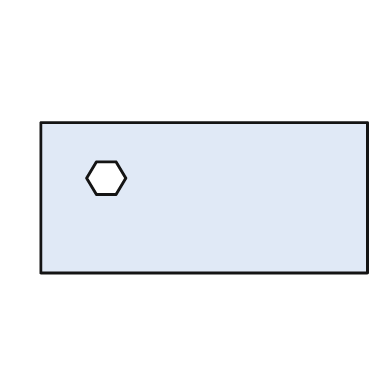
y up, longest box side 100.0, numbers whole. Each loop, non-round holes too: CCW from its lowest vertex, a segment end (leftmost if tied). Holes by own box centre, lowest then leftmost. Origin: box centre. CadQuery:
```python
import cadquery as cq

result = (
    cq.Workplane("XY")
    .moveTo(-50.0, -23.0)
    .lineTo(50.0, -23.0)
    .lineTo(50.0, 23.0)
    .lineTo(-50.0, 23.0)
    .close()
    .moveTo(-33.0, 1.0)
    .lineTo(-27.0, 1.0)
    .lineTo(-24.0, 6.0)
    .lineTo(-27.0, 11.0)
    .lineTo(-33.0, 11.0)
    .lineTo(-36.0, 6.0)
    .close()
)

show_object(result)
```